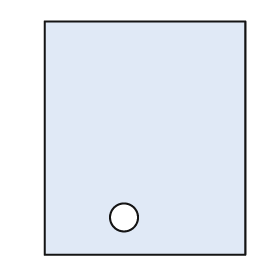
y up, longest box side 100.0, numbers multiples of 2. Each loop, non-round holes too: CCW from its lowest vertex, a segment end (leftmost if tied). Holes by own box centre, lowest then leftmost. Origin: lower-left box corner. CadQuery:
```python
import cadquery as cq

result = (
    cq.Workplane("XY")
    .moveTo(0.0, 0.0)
    .lineTo(86.0, 0.0)
    .lineTo(86.0, 100.0)
    .lineTo(0.0, 100.0)
    .close()
    .moveTo(34.0, 16.0)
    .circle(6.0)
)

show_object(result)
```